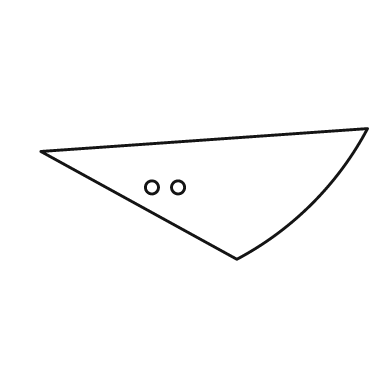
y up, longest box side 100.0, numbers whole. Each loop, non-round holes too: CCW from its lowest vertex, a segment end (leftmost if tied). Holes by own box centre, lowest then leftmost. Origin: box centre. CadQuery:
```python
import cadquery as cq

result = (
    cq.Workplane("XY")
    .moveTo(10.0, -20.0)
    .threePointArc((33.0, -3.0), (50.0, 20.0))
    .lineTo(-50.0, 13.0)
    .close()
    .moveTo(-16.0, 2.0)
    .circle(2.0)
    .moveTo(-8.0, 2.0)
    .circle(2.0)
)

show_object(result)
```